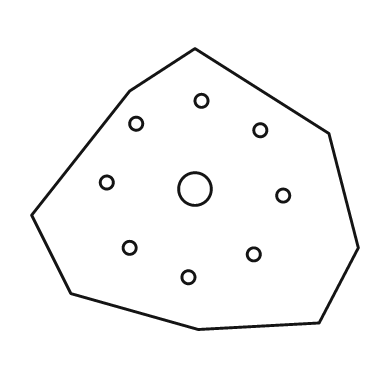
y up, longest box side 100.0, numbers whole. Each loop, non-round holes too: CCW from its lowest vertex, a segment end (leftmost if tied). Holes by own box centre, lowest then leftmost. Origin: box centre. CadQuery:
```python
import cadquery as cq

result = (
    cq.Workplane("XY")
    .moveTo(1.0, -43.0)
    .lineTo(38.0, -41.0)
    .lineTo(50.0, -18.0)
    .lineTo(41.0, 17.0)
    .lineTo(0.0, 43.0)
    .lineTo(-20.0, 30.0)
    .lineTo(-50.0, -8.0)
    .lineTo(-38.0, -32.0)
    .close()
    .moveTo(-2.0, -27.0)
    .circle(2.0)
    .moveTo(18.0, -20.0)
    .circle(2.0)
    .moveTo(-20.0, -18.0)
    .circle(2.0)
    .moveTo(27.0, -2.0)
    .circle(2.0)
    .moveTo(0.0, 0.0)
    .circle(5.0)
    .moveTo(-27.0, 2.0)
    .circle(2.0)
    .moveTo(20.0, 18.0)
    .circle(2.0)
    .moveTo(-18.0, 20.0)
    .circle(2.0)
    .moveTo(2.0, 27.0)
    .circle(2.0)
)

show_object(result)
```